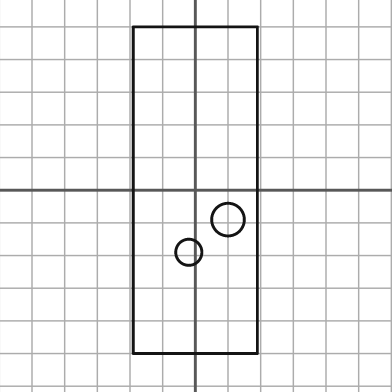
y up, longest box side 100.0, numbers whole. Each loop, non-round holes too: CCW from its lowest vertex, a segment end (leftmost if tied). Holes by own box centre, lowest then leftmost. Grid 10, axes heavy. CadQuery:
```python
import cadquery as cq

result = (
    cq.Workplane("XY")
    .moveTo(-19.0, -50.0)
    .lineTo(19.0, -50.0)
    .lineTo(19.0, 50.0)
    .lineTo(-19.0, 50.0)
    .close()
    .moveTo(-2.0, -19.0)
    .circle(4.0)
    .moveTo(10.0, -9.0)
    .circle(5.0)
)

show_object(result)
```